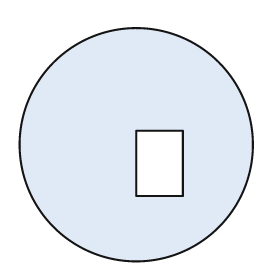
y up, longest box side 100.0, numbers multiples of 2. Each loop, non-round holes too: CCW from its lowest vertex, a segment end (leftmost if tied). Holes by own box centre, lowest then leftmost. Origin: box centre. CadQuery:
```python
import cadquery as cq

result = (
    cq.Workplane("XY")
    .moveTo(0.0, 0.0)
    .circle(50.0)
    .moveTo(0.0, -22.0)
    .lineTo(20.0, -22.0)
    .lineTo(20.0, 6.0)
    .lineTo(0.0, 6.0)
    .close()
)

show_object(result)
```